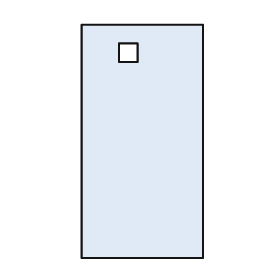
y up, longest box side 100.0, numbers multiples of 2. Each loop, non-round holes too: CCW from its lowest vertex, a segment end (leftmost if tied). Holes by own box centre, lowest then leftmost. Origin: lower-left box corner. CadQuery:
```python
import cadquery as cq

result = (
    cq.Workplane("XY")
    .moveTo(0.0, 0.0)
    .lineTo(52.0, 0.0)
    .lineTo(52.0, 100.0)
    .lineTo(0.0, 100.0)
    .close()
    .moveTo(16.0, 84.0)
    .lineTo(24.0, 84.0)
    .lineTo(24.0, 92.0)
    .lineTo(16.0, 92.0)
    .close()
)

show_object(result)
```